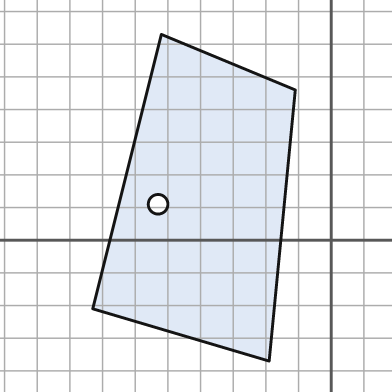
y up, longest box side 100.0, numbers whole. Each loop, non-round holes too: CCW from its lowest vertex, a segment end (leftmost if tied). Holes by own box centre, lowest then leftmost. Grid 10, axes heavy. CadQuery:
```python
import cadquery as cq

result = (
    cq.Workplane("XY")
    .moveTo(-19.0, -37.0)
    .lineTo(-11.0, 46.0)
    .lineTo(-52.0, 63.0)
    .lineTo(-73.0, -21.0)
    .close()
    .moveTo(-53.0, 11.0)
    .circle(3.0)
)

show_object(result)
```